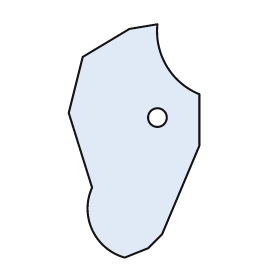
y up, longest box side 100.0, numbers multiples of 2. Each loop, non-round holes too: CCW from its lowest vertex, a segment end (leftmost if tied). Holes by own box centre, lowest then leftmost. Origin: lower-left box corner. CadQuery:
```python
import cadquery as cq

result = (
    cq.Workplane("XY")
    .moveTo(24.0, 0.0)
    .lineTo(34.0, 4.0)
    .lineTo(40.0, 10.0)
    .lineTo(56.0, 48.0)
    .lineTo(56.0, 70.0)
    .threePointArc((42.0, 82.0), (38.0, 100.0))
    .lineTo(26.0, 98.0)
    .lineTo(6.0, 86.0)
    .lineTo(0.0, 62.0)
    .lineTo(10.0, 30.0)
    .threePointArc((10.0, 12.0), (24.0, 0.0))
    .close()
    .moveTo(38.0, 60.0)
    .circle(4.0)
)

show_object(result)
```